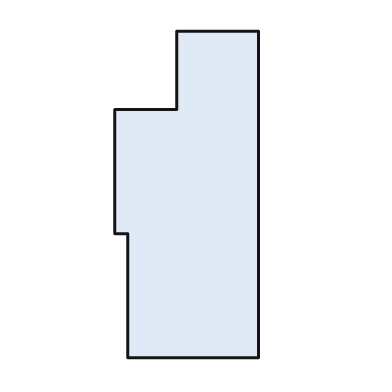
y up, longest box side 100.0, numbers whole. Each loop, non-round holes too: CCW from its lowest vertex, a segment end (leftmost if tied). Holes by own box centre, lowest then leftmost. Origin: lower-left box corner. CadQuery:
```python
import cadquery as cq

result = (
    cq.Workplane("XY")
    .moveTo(4.0, 0.0)
    .lineTo(44.0, 0.0)
    .lineTo(44.0, 100.0)
    .lineTo(19.0, 100.0)
    .lineTo(19.0, 76.0)
    .lineTo(0.0, 76.0)
    .lineTo(0.0, 38.0)
    .lineTo(4.0, 38.0)
    .close()
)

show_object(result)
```